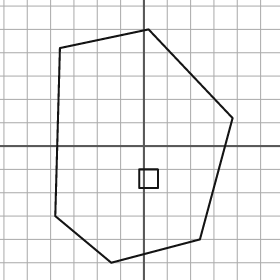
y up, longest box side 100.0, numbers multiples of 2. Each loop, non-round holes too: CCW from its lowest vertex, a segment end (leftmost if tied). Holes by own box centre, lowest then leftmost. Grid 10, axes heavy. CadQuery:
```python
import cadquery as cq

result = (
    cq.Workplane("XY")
    .moveTo(-14.0, -50.0)
    .lineTo(24.0, -40.0)
    .lineTo(38.0, 12.0)
    .lineTo(2.0, 50.0)
    .lineTo(-36.0, 42.0)
    .lineTo(-38.0, -30.0)
    .close()
    .moveTo(-2.0, -18.0)
    .lineTo(6.0, -18.0)
    .lineTo(6.0, -10.0)
    .lineTo(-2.0, -10.0)
    .close()
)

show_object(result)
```